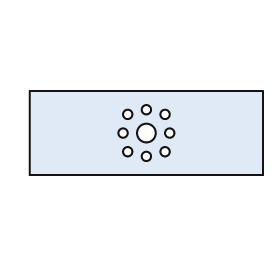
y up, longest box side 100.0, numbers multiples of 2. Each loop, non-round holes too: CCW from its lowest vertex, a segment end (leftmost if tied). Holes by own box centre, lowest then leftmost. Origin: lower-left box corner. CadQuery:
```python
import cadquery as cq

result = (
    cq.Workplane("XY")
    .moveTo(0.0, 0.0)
    .lineTo(100.0, 0.0)
    .lineTo(100.0, 36.0)
    .lineTo(0.0, 36.0)
    .close()
    .moveTo(50.0, 8.0)
    .circle(2.0)
    .moveTo(42.0, 10.0)
    .circle(2.0)
    .moveTo(58.0, 10.0)
    .circle(2.0)
    .moveTo(40.0, 18.0)
    .circle(2.0)
    .moveTo(50.0, 18.0)
    .circle(4.0)
    .moveTo(60.0, 18.0)
    .circle(2.0)
    .moveTo(42.0, 26.0)
    .circle(2.0)
    .moveTo(58.0, 26.0)
    .circle(2.0)
    .moveTo(50.0, 28.0)
    .circle(2.0)
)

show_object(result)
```